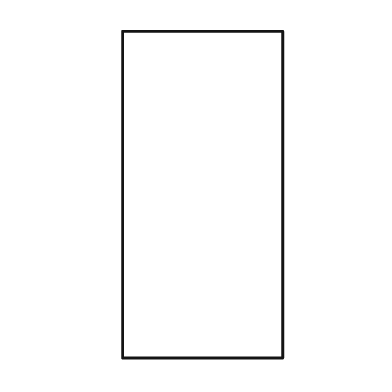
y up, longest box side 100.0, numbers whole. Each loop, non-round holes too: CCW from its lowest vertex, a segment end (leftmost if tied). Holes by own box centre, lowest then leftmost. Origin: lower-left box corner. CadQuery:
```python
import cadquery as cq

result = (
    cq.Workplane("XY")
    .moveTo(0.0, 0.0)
    .lineTo(49.0, 0.0)
    .lineTo(49.0, 100.0)
    .lineTo(0.0, 100.0)
    .close()
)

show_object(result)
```